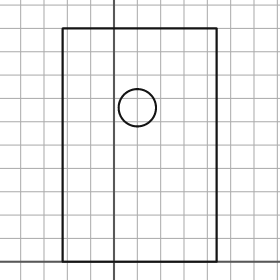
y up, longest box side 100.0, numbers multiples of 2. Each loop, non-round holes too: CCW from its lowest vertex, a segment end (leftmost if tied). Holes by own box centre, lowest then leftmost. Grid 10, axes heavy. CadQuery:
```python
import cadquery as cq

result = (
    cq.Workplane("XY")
    .moveTo(-22.0, 0.0)
    .lineTo(44.0, 0.0)
    .lineTo(44.0, 100.0)
    .lineTo(-22.0, 100.0)
    .close()
    .moveTo(10.0, 66.0)
    .circle(8.0)
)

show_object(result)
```